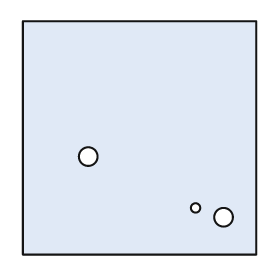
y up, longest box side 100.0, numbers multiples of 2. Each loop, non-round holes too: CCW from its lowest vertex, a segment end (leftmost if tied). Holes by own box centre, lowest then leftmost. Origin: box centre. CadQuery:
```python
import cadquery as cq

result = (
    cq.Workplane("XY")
    .moveTo(-50.0, -50.0)
    .lineTo(50.0, -50.0)
    .lineTo(50.0, 50.0)
    .lineTo(-50.0, 50.0)
    .close()
    .moveTo(36.0, -34.0)
    .circle(4.0)
    .moveTo(24.0, -30.0)
    .circle(2.0)
    .moveTo(-22.0, -8.0)
    .circle(4.0)
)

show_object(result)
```